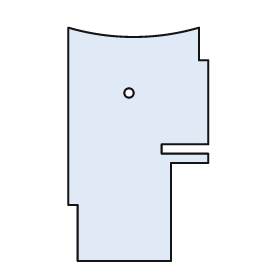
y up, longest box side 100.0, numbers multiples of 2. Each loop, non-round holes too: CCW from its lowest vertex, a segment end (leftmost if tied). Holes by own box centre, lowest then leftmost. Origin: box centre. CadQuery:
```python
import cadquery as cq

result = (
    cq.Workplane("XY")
    .moveTo(-26.0, -50.0)
    .lineTo(14.0, -50.0)
    .lineTo(14.0, -8.0)
    .lineTo(30.0, -8.0)
    .lineTo(30.0, -4.0)
    .lineTo(10.0, -4.0)
    .lineTo(10.0, 0.0)
    .lineTo(30.0, 0.0)
    .lineTo(30.0, 36.0)
    .lineTo(26.0, 36.0)
    .lineTo(26.0, 50.0)
    .threePointArc((-2.0, 46.0), (-30.0, 50.0))
    .lineTo(-30.0, -26.0)
    .lineTo(-26.0, -26.0)
    .close()
    .moveTo(-4.0, 22.0)
    .circle(2.0)
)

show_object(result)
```